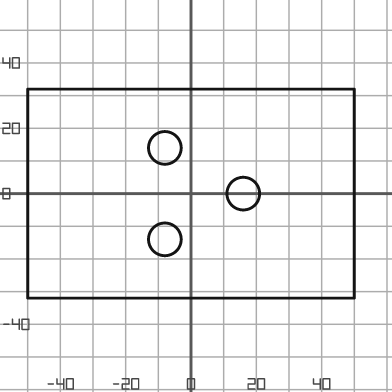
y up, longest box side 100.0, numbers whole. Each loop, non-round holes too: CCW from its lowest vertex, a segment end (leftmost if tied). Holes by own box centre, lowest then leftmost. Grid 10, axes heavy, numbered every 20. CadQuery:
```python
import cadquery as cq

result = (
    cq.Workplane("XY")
    .moveTo(-50.0, -32.0)
    .lineTo(50.0, -32.0)
    .lineTo(50.0, 32.0)
    .lineTo(-50.0, 32.0)
    .close()
    .moveTo(-8.0, -14.0)
    .circle(5.0)
    .moveTo(16.0, 0.0)
    .circle(5.0)
    .moveTo(-8.0, 14.0)
    .circle(5.0)
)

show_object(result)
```